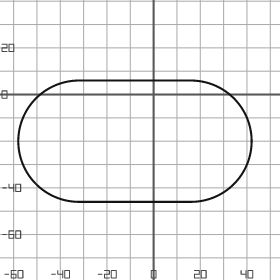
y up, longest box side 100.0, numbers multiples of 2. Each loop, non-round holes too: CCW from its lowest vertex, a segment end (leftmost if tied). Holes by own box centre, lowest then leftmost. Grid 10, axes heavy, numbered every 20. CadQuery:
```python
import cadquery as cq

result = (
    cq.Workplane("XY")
    .moveTo(-32.0, -46.0)
    .lineTo(16.0, -46.0)
    .threePointArc((42.0, -20.0), (16.0, 6.0))
    .lineTo(-32.0, 6.0)
    .threePointArc((-58.0, -20.0), (-32.0, -46.0))
    .close()
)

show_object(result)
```